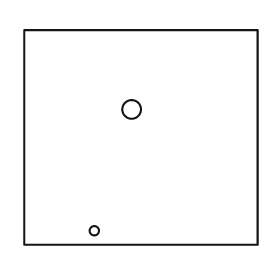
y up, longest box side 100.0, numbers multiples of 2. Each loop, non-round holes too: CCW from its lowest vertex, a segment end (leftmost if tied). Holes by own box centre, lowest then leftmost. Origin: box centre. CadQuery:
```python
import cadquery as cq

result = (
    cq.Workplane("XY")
    .moveTo(-50.0, -46.0)
    .lineTo(50.0, -46.0)
    .lineTo(50.0, 46.0)
    .lineTo(-50.0, 46.0)
    .close()
    .moveTo(-20.0, -40.0)
    .circle(2.0)
    .moveTo(-4.0, 12.0)
    .circle(4.0)
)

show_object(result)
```